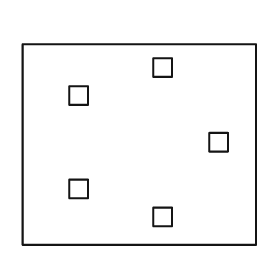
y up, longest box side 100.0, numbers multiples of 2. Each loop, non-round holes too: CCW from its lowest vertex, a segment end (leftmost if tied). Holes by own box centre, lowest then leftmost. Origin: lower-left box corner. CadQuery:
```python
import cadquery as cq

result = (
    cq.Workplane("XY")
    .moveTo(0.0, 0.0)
    .lineTo(100.0, 0.0)
    .lineTo(100.0, 86.0)
    .lineTo(0.0, 86.0)
    .close()
    .moveTo(56.0, 8.0)
    .lineTo(64.0, 8.0)
    .lineTo(64.0, 16.0)
    .lineTo(56.0, 16.0)
    .close()
    .moveTo(20.0, 20.0)
    .lineTo(28.0, 20.0)
    .lineTo(28.0, 28.0)
    .lineTo(20.0, 28.0)
    .close()
    .moveTo(80.0, 40.0)
    .lineTo(88.0, 40.0)
    .lineTo(88.0, 48.0)
    .lineTo(80.0, 48.0)
    .close()
    .moveTo(20.0, 60.0)
    .lineTo(28.0, 60.0)
    .lineTo(28.0, 68.0)
    .lineTo(20.0, 68.0)
    .close()
    .moveTo(56.0, 72.0)
    .lineTo(64.0, 72.0)
    .lineTo(64.0, 80.0)
    .lineTo(56.0, 80.0)
    .close()
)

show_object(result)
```